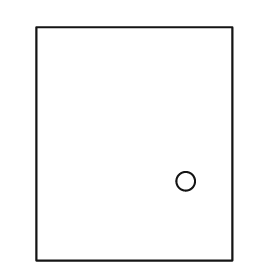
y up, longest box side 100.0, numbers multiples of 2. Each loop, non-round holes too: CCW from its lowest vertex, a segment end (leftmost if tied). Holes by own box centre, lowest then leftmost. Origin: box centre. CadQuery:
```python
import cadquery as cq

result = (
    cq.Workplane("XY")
    .moveTo(-42.0, -50.0)
    .lineTo(42.0, -50.0)
    .lineTo(42.0, 50.0)
    .lineTo(-42.0, 50.0)
    .close()
    .moveTo(22.0, -16.0)
    .circle(4.0)
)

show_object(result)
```